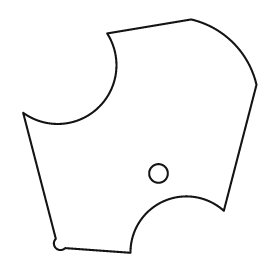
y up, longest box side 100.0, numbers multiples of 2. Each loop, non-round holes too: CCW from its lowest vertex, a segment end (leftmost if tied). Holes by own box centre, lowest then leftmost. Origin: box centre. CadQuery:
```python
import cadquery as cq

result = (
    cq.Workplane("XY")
    .moveTo(-4.0, -50.0)
    .threePointArc((10.0, -28.0), (36.0, -32.0))
    .lineTo(50.0, 22.0)
    .threePointArc((40.0, 40.0), (22.0, 50.0))
    .lineTo(-14.0, 44.0)
    .threePointArc((-18.0, 12.0), (-50.0, 10.0))
    .lineTo(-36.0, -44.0)
    .threePointArc((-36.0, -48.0), (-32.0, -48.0))
    .close()
    .moveTo(8.0, -16.0)
    .circle(4.0)
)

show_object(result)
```